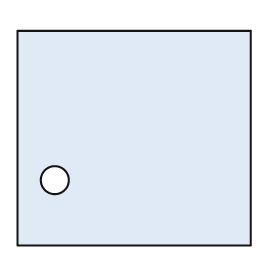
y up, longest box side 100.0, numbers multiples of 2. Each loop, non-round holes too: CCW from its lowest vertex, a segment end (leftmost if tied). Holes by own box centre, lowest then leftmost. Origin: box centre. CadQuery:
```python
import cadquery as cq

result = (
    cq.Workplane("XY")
    .moveTo(-50.0, -46.0)
    .lineTo(50.0, -46.0)
    .lineTo(50.0, 46.0)
    .lineTo(-50.0, 46.0)
    .close()
    .moveTo(-34.0, -18.0)
    .circle(6.0)
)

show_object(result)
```